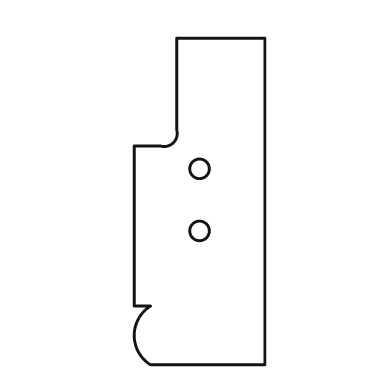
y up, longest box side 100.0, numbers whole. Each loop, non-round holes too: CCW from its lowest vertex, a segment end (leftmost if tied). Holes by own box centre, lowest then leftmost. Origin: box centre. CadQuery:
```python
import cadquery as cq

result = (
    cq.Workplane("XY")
    .moveTo(-15.0, -50.0)
    .lineTo(20.0, -50.0)
    .lineTo(20.0, 50.0)
    .lineTo(-7.0, 50.0)
    .lineTo(-7.0, 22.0)
    .threePointArc((-8.0, 18.0), (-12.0, 17.0))
    .lineTo(-20.0, 17.0)
    .lineTo(-20.0, -32.0)
    .lineTo(-15.0, -32.0)
    .threePointArc((-20.0, -41.0), (-15.0, -50.0))
    .close()
    .moveTo(0.0, -9.0)
    .circle(3.0)
    .moveTo(0.0, 10.0)
    .circle(3.0)
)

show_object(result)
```